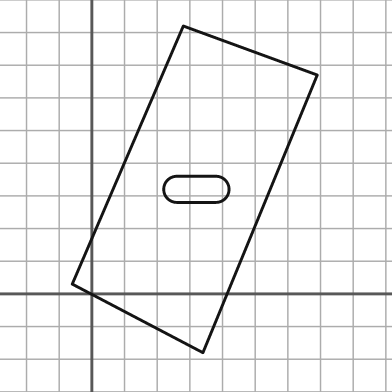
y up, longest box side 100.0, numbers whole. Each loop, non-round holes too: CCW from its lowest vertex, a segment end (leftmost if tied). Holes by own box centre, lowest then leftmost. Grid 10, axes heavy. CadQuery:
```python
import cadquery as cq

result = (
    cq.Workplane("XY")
    .moveTo(34.0, -18.0)
    .lineTo(69.0, 67.0)
    .lineTo(28.0, 82.0)
    .lineTo(-6.0, 3.0)
    .close()
    .moveTo(26.0, 28.0)
    .lineTo(38.0, 28.0)
    .threePointArc((42.0, 32.0), (38.0, 36.0))
    .lineTo(26.0, 36.0)
    .threePointArc((22.0, 32.0), (26.0, 28.0))
    .close()
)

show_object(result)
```